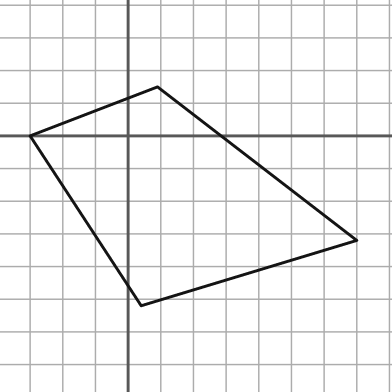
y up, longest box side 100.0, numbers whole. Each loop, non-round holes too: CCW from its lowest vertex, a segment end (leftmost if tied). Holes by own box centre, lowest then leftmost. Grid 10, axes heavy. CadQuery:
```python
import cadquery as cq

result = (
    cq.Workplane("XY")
    .moveTo(4.0, -52.0)
    .lineTo(70.0, -32.0)
    .lineTo(9.0, 15.0)
    .lineTo(-30.0, 0.0)
    .close()
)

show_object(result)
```